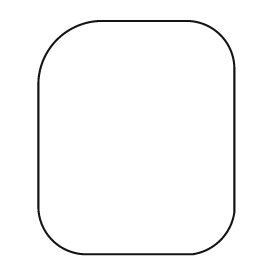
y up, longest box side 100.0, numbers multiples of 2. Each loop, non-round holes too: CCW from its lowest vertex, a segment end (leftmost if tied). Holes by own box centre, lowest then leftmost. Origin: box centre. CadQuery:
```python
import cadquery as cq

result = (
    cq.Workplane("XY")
    .moveTo(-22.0, -50.0)
    .lineTo(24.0, -50.0)
    .threePointArc((36.0, -44.0), (42.0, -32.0))
    .lineTo(42.0, 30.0)
    .threePointArc((36.0, 44.0), (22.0, 50.0))
    .lineTo(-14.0, 50.0)
    .threePointArc((-34.0, 42.0), (-42.0, 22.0))
    .lineTo(-42.0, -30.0)
    .threePointArc((-36.0, -44.0), (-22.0, -50.0))
    .close()
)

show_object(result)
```